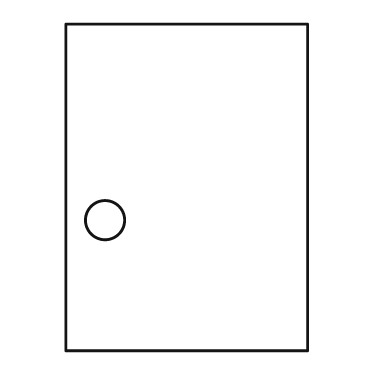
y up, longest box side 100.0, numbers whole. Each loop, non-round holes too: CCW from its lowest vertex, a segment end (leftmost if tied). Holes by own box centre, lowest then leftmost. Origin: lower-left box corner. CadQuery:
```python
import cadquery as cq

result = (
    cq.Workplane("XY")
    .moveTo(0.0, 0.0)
    .lineTo(74.0, 0.0)
    .lineTo(74.0, 100.0)
    .lineTo(0.0, 100.0)
    .close()
    .moveTo(12.0, 40.0)
    .circle(6.0)
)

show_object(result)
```